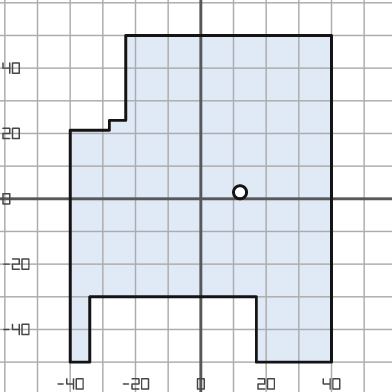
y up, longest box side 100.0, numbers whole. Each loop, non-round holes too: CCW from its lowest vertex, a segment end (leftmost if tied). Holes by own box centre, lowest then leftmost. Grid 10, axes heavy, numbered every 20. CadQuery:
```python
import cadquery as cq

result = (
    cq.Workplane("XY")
    .moveTo(-40.0, -50.0)
    .lineTo(-34.0, -50.0)
    .lineTo(-34.0, -30.0)
    .lineTo(17.0, -30.0)
    .lineTo(17.0, -50.0)
    .lineTo(40.0, -50.0)
    .lineTo(40.0, 50.0)
    .lineTo(-23.0, 50.0)
    .lineTo(-23.0, 24.0)
    .lineTo(-28.0, 24.0)
    .lineTo(-28.0, 21.0)
    .lineTo(-40.0, 21.0)
    .close()
    .moveTo(12.0, 2.0)
    .circle(2.0)
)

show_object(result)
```